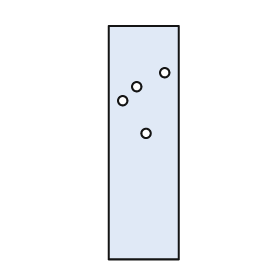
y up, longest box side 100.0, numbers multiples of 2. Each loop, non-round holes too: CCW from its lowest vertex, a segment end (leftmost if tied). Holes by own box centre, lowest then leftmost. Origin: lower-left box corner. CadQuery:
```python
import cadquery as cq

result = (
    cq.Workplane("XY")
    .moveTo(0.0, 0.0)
    .lineTo(30.0, 0.0)
    .lineTo(30.0, 100.0)
    .lineTo(0.0, 100.0)
    .close()
    .moveTo(16.0, 54.0)
    .circle(2.0)
    .moveTo(6.0, 68.0)
    .circle(2.0)
    .moveTo(12.0, 74.0)
    .circle(2.0)
    .moveTo(24.0, 80.0)
    .circle(2.0)
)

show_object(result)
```